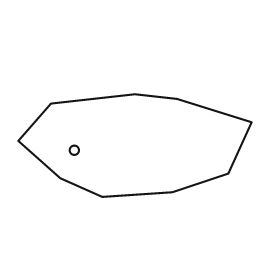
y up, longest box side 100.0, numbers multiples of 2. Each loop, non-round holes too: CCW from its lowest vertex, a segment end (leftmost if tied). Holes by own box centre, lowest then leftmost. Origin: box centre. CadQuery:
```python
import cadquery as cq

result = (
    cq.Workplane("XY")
    .moveTo(-14.0, -22.0)
    .lineTo(16.0, -20.0)
    .lineTo(40.0, -12.0)
    .lineTo(50.0, 10.0)
    .lineTo(18.0, 20.0)
    .lineTo(0.0, 22.0)
    .lineTo(-36.0, 18.0)
    .lineTo(-50.0, 2.0)
    .lineTo(-32.0, -14.0)
    .close()
    .moveTo(-26.0, -2.0)
    .circle(2.0)
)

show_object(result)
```